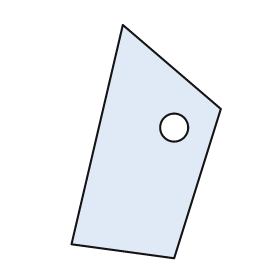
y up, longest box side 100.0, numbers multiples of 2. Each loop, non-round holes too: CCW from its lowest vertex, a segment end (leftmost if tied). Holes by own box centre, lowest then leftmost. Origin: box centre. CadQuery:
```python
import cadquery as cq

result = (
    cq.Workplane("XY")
    .moveTo(12.0, -50.0)
    .lineTo(32.0, 14.0)
    .lineTo(-10.0, 50.0)
    .lineTo(-32.0, -44.0)
    .close()
    .moveTo(12.0, 6.0)
    .circle(6.0)
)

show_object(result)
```